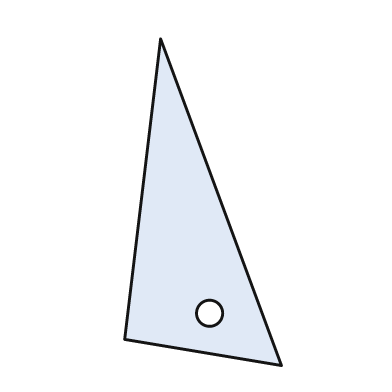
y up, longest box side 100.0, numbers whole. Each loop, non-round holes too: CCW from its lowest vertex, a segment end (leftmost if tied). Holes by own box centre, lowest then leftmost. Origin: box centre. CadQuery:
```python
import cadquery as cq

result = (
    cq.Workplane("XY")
    .moveTo(24.0, -50.0)
    .lineTo(-13.0, 50.0)
    .lineTo(-24.0, -42.0)
    .close()
    .moveTo(2.0, -34.0)
    .circle(4.0)
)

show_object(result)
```